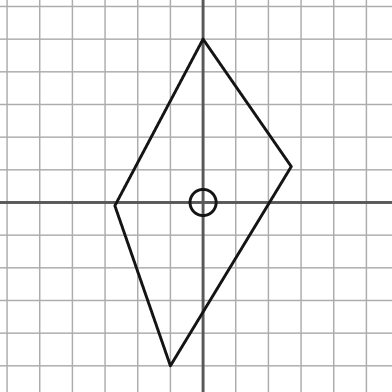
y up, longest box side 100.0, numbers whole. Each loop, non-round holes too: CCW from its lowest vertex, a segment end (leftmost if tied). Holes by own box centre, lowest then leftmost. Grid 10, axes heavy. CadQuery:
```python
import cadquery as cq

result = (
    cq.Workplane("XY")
    .moveTo(-10.0, -50.0)
    .lineTo(27.0, 11.0)
    .lineTo(0.0, 50.0)
    .lineTo(-27.0, -1.0)
    .close()
    .moveTo(0.0, 0.0)
    .circle(4.0)
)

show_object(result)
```